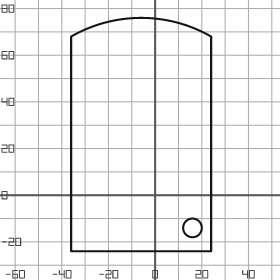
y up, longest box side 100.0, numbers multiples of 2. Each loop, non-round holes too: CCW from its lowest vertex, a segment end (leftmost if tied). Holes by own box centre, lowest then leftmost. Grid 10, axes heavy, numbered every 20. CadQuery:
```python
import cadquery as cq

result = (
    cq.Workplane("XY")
    .moveTo(-36.0, -24.0)
    .lineTo(24.0, -24.0)
    .lineTo(24.0, 68.0)
    .threePointArc((-6.0, 76.0), (-36.0, 68.0))
    .close()
    .moveTo(16.0, -14.0)
    .circle(4.0)
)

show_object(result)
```